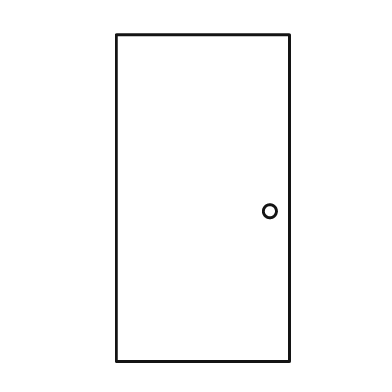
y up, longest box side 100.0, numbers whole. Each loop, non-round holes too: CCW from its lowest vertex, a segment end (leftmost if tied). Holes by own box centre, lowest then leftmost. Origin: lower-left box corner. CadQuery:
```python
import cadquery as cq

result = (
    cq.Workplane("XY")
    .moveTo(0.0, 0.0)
    .lineTo(53.0, 0.0)
    .lineTo(53.0, 100.0)
    .lineTo(0.0, 100.0)
    .close()
    .moveTo(47.0, 46.0)
    .circle(2.0)
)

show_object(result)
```